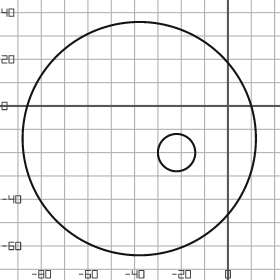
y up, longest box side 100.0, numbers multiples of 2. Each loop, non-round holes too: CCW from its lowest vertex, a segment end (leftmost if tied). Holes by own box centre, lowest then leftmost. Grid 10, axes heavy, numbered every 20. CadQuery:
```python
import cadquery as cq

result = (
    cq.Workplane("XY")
    .moveTo(-38.0, -14.0)
    .circle(50.0)
    .moveTo(-22.0, -20.0)
    .circle(8.0)
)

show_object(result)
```